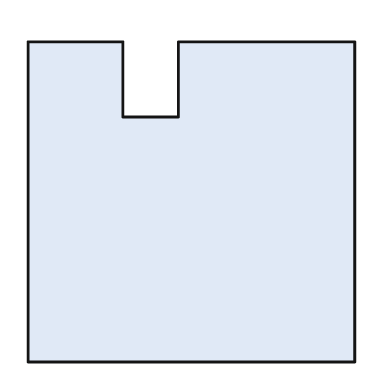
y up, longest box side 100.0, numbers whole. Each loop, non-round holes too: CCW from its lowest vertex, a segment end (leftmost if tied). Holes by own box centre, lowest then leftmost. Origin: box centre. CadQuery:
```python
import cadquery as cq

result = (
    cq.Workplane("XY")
    .moveTo(-50.0, -49.0)
    .lineTo(50.0, -49.0)
    .lineTo(50.0, 49.0)
    .lineTo(-4.0, 49.0)
    .lineTo(-4.0, 26.0)
    .lineTo(-21.0, 26.0)
    .lineTo(-21.0, 49.0)
    .lineTo(-50.0, 49.0)
    .close()
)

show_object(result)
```